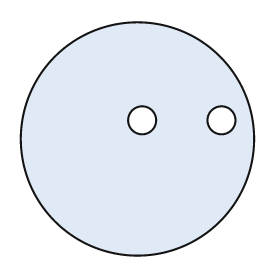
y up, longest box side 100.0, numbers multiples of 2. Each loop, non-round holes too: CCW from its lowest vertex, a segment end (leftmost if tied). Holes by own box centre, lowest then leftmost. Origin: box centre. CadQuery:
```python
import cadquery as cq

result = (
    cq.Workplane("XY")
    .moveTo(0.0, 0.0)
    .circle(50.0)
    .moveTo(2.0, 8.0)
    .circle(6.0)
    .moveTo(36.0, 8.0)
    .circle(6.0)
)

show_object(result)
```